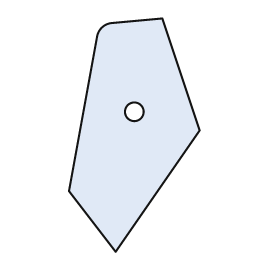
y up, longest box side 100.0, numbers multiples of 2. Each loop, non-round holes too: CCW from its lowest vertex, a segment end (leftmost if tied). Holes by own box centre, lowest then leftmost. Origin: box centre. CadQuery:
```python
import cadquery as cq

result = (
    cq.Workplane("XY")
    .moveTo(-8.0, -50.0)
    .lineTo(28.0, 2.0)
    .lineTo(12.0, 50.0)
    .lineTo(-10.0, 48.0)
    .threePointArc((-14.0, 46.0), (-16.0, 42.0))
    .lineTo(-28.0, -24.0)
    .close()
    .moveTo(0.0, 10.0)
    .circle(4.0)
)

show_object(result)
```